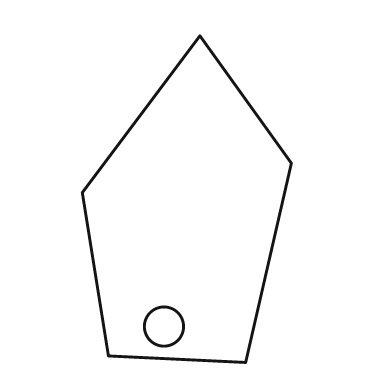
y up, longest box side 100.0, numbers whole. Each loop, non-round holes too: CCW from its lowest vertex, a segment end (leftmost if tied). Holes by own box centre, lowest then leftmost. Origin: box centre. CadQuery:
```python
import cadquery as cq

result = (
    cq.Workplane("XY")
    .moveTo(18.0, -50.0)
    .lineTo(32.0, 11.0)
    .lineTo(4.0, 50.0)
    .lineTo(-32.0, 2.0)
    .lineTo(-24.0, -48.0)
    .close()
    .moveTo(-7.0, -39.0)
    .circle(6.0)
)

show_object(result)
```